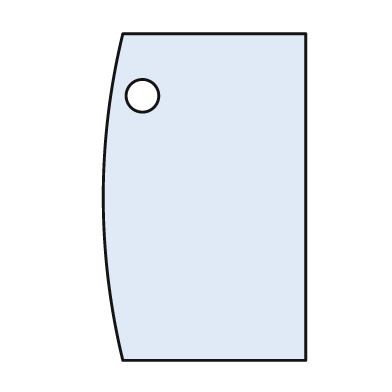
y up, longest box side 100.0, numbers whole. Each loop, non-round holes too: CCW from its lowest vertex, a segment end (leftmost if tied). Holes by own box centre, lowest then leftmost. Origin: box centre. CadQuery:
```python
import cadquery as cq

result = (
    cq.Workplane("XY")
    .moveTo(-25.0, -50.0)
    .lineTo(31.0, -50.0)
    .lineTo(31.0, 50.0)
    .lineTo(-25.0, 50.0)
    .threePointArc((-31.0, 0.0), (-25.0, -50.0))
    .close()
    .moveTo(-19.0, 31.0)
    .circle(5.0)
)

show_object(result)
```